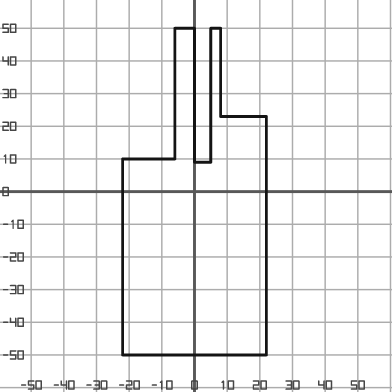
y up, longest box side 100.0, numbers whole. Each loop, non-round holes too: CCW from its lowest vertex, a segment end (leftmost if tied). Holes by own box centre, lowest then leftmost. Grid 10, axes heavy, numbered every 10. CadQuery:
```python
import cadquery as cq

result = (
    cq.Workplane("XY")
    .moveTo(-22.0, -50.0)
    .lineTo(22.0, -50.0)
    .lineTo(22.0, 23.0)
    .lineTo(8.0, 23.0)
    .lineTo(8.0, 50.0)
    .lineTo(5.0, 50.0)
    .lineTo(5.0, 9.0)
    .lineTo(0.0, 9.0)
    .lineTo(0.0, 50.0)
    .lineTo(-6.0, 50.0)
    .lineTo(-6.0, 10.0)
    .lineTo(-22.0, 10.0)
    .close()
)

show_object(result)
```